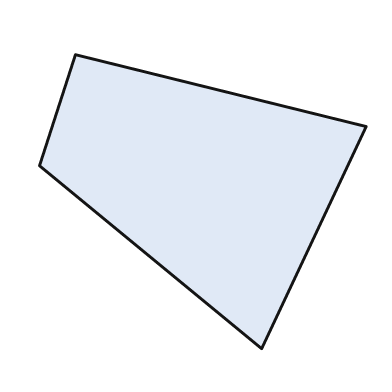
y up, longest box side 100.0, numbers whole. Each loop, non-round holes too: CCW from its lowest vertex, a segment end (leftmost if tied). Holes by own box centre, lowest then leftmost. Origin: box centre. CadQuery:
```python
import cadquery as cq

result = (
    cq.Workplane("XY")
    .moveTo(18.0, -45.0)
    .lineTo(50.0, 23.0)
    .lineTo(-39.0, 45.0)
    .lineTo(-50.0, 11.0)
    .close()
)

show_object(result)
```